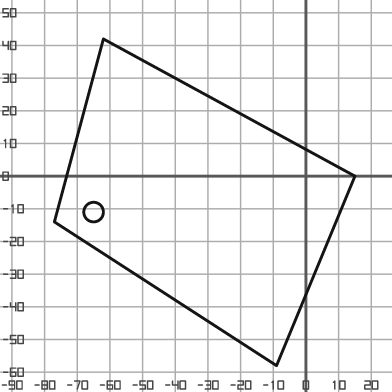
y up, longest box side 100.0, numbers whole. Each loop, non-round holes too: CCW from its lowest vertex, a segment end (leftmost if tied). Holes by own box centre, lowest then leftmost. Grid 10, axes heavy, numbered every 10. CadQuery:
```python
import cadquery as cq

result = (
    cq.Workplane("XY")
    .moveTo(-9.0, -58.0)
    .lineTo(15.0, 0.0)
    .lineTo(-62.0, 42.0)
    .lineTo(-77.0, -14.0)
    .close()
    .moveTo(-65.0, -11.0)
    .circle(3.0)
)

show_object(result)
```